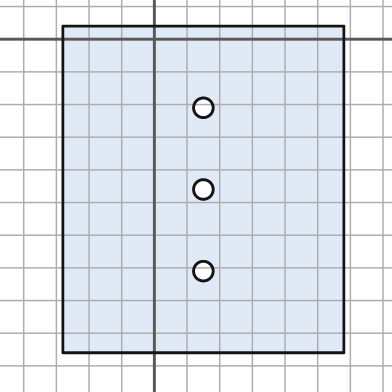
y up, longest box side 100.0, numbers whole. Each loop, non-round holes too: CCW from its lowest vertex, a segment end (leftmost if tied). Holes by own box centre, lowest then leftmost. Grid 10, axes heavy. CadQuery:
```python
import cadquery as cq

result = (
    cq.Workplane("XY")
    .moveTo(-28.0, -96.0)
    .lineTo(58.0, -96.0)
    .lineTo(58.0, 4.0)
    .lineTo(-28.0, 4.0)
    .close()
    .moveTo(15.0, -71.0)
    .circle(3.0)
    .moveTo(15.0, -46.0)
    .circle(3.0)
    .moveTo(15.0, -21.0)
    .circle(3.0)
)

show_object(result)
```